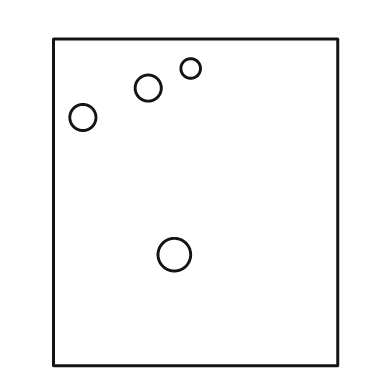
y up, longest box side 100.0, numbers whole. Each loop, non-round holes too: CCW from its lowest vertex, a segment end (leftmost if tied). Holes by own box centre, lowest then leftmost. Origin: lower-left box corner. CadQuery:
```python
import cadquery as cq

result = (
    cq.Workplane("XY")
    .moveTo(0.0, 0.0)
    .lineTo(87.0, 0.0)
    .lineTo(87.0, 100.0)
    .lineTo(0.0, 100.0)
    .close()
    .moveTo(37.0, 34.0)
    .circle(5.0)
    .moveTo(9.0, 76.0)
    .circle(4.0)
    .moveTo(29.0, 85.0)
    .circle(4.0)
    .moveTo(42.0, 91.0)
    .circle(3.0)
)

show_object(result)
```